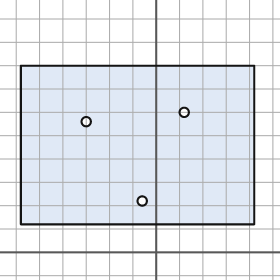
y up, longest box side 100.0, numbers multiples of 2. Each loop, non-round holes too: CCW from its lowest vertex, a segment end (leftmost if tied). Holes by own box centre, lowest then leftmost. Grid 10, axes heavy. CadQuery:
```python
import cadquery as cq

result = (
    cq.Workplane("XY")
    .moveTo(-58.0, 12.0)
    .lineTo(42.0, 12.0)
    .lineTo(42.0, 80.0)
    .lineTo(-58.0, 80.0)
    .close()
    .moveTo(-6.0, 22.0)
    .circle(2.0)
    .moveTo(-30.0, 56.0)
    .circle(2.0)
    .moveTo(12.0, 60.0)
    .circle(2.0)
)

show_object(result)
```